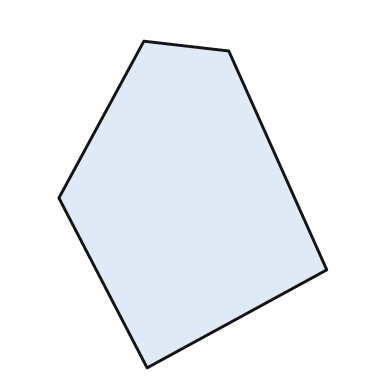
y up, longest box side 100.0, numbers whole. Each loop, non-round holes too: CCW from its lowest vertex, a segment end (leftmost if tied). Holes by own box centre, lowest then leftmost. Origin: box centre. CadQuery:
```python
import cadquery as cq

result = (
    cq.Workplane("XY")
    .moveTo(-14.0, -50.0)
    .lineTo(41.0, -20.0)
    .lineTo(11.0, 47.0)
    .lineTo(-15.0, 50.0)
    .lineTo(-41.0, 2.0)
    .close()
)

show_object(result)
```